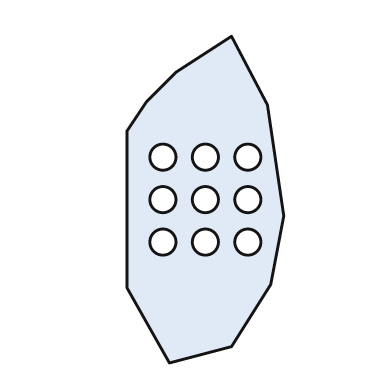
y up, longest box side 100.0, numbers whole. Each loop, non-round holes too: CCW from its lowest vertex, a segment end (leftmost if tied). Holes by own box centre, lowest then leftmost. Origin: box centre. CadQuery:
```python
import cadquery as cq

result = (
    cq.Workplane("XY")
    .moveTo(-11.0, -50.0)
    .lineTo(8.0, -45.0)
    .lineTo(20.0, -26.0)
    .lineTo(24.0, -5.0)
    .lineTo(19.0, 29.0)
    .lineTo(8.0, 50.0)
    .lineTo(-9.0, 39.0)
    .lineTo(-18.0, 30.0)
    .lineTo(-24.0, 21.0)
    .lineTo(-24.0, -27.0)
    .close()
    .moveTo(-13.0, -13.0)
    .circle(4.0)
    .moveTo(0.0, -13.0)
    .circle(4.0)
    .moveTo(13.0, -13.0)
    .circle(4.0)
    .moveTo(-13.0, 0.0)
    .circle(4.0)
    .moveTo(0.0, 0.0)
    .circle(4.0)
    .moveTo(13.0, 0.0)
    .circle(4.0)
    .moveTo(-13.0, 13.0)
    .circle(4.0)
    .moveTo(0.0, 13.0)
    .circle(4.0)
    .moveTo(13.0, 13.0)
    .circle(4.0)
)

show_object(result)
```